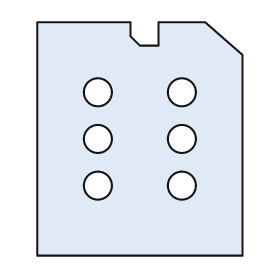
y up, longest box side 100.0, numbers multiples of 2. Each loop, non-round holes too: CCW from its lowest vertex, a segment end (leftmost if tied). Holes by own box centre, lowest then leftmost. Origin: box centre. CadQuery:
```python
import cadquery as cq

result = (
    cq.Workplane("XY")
    .moveTo(-44.0, -50.0)
    .lineTo(44.0, -50.0)
    .lineTo(44.0, 36.0)
    .lineTo(28.0, 50.0)
    .lineTo(8.0, 50.0)
    .lineTo(8.0, 40.0)
    .lineTo(0.0, 40.0)
    .lineTo(-4.0, 44.0)
    .lineTo(-4.0, 50.0)
    .lineTo(-44.0, 50.0)
    .close()
    .moveTo(-18.0, -20.0)
    .circle(6.0)
    .moveTo(18.0, -20.0)
    .circle(6.0)
    .moveTo(-18.0, 0.0)
    .circle(6.0)
    .moveTo(18.0, 0.0)
    .circle(6.0)
    .moveTo(-18.0, 20.0)
    .circle(6.0)
    .moveTo(18.0, 20.0)
    .circle(6.0)
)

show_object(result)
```